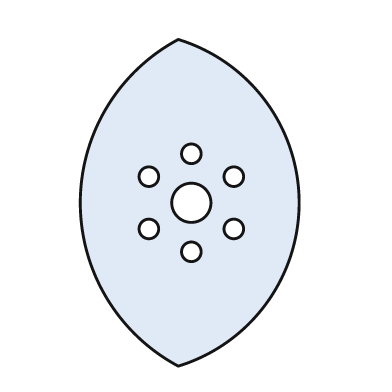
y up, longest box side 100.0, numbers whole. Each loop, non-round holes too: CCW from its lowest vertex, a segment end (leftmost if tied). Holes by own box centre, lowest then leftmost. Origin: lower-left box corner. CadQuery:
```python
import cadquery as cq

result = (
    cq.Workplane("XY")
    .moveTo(30.0, 0.0)
    .threePointArc((67.0, 50.0), (30.0, 100.0))
    .threePointArc((0.0, 50.0), (30.0, 0.0))
    .close()
    .moveTo(34.0, 35.0)
    .circle(3.0)
    .moveTo(21.0, 42.0)
    .circle(3.0)
    .moveTo(47.0, 42.0)
    .circle(3.0)
    .moveTo(34.0, 50.0)
    .circle(6.0)
    .moveTo(21.0, 58.0)
    .circle(3.0)
    .moveTo(47.0, 58.0)
    .circle(3.0)
    .moveTo(34.0, 65.0)
    .circle(3.0)
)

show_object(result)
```